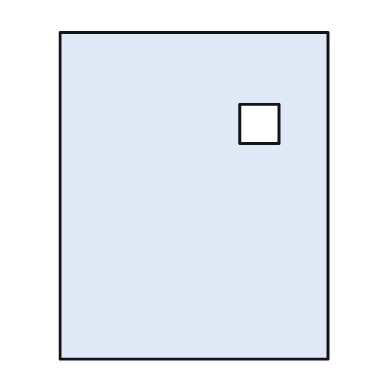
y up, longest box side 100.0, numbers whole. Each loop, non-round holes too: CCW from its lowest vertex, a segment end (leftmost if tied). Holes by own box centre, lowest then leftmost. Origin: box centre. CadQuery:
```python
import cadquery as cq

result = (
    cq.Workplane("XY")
    .moveTo(-41.0, -50.0)
    .lineTo(41.0, -50.0)
    .lineTo(41.0, 50.0)
    .lineTo(-41.0, 50.0)
    .close()
    .moveTo(14.0, 16.0)
    .lineTo(26.0, 16.0)
    .lineTo(26.0, 28.0)
    .lineTo(14.0, 28.0)
    .close()
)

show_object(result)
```